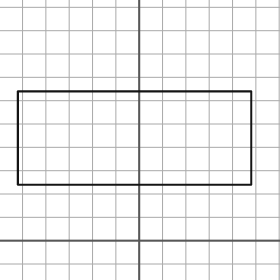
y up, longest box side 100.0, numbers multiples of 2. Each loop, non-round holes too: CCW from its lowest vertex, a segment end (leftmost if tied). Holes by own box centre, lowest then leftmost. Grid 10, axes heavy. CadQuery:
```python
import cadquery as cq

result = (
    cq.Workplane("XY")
    .moveTo(-52.0, 24.0)
    .lineTo(48.0, 24.0)
    .lineTo(48.0, 64.0)
    .lineTo(-52.0, 64.0)
    .close()
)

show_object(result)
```